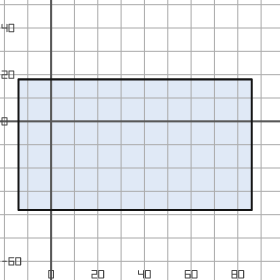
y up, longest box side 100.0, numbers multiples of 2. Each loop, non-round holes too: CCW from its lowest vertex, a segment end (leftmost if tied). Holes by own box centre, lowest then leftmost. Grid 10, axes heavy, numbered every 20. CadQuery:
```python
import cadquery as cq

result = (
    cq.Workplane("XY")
    .moveTo(-14.0, -38.0)
    .lineTo(86.0, -38.0)
    .lineTo(86.0, 18.0)
    .lineTo(-14.0, 18.0)
    .close()
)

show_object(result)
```